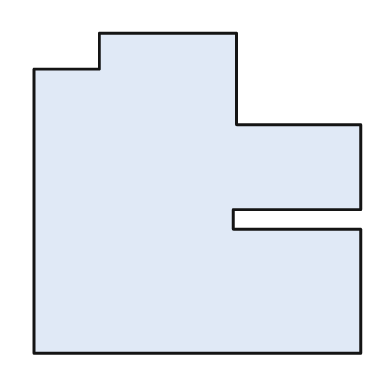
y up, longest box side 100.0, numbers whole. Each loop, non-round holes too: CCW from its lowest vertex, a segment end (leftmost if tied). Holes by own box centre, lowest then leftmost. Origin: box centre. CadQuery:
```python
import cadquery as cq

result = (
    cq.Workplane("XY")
    .moveTo(-50.0, -49.0)
    .lineTo(50.0, -49.0)
    .lineTo(50.0, -11.0)
    .lineTo(11.0, -11.0)
    .lineTo(11.0, -5.0)
    .lineTo(50.0, -5.0)
    .lineTo(50.0, 21.0)
    .lineTo(12.0, 21.0)
    .lineTo(12.0, 49.0)
    .lineTo(-30.0, 49.0)
    .lineTo(-30.0, 38.0)
    .lineTo(-50.0, 38.0)
    .close()
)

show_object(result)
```